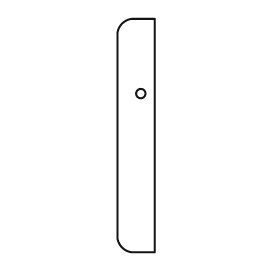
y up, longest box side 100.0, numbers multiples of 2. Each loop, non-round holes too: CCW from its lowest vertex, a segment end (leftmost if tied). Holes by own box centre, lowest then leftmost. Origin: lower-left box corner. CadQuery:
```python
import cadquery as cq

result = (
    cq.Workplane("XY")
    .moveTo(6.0, 0.0)
    .lineTo(16.0, 0.0)
    .lineTo(16.0, 100.0)
    .lineTo(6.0, 100.0)
    .threePointArc((2.0, 98.0), (0.0, 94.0))
    .lineTo(0.0, 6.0)
    .threePointArc((2.0, 2.0), (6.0, 0.0))
    .close()
    .moveTo(10.0, 68.0)
    .circle(2.0)
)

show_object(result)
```